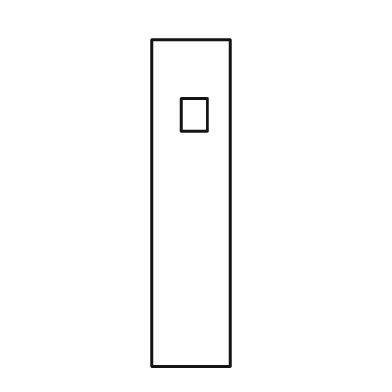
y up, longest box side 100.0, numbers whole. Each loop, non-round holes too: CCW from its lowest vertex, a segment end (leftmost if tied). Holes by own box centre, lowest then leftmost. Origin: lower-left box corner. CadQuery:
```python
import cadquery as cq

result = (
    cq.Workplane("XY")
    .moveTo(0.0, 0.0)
    .lineTo(24.0, 0.0)
    .lineTo(24.0, 100.0)
    .lineTo(0.0, 100.0)
    .close()
    .moveTo(9.0, 72.0)
    .lineTo(17.0, 72.0)
    .lineTo(17.0, 82.0)
    .lineTo(9.0, 82.0)
    .close()
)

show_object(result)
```